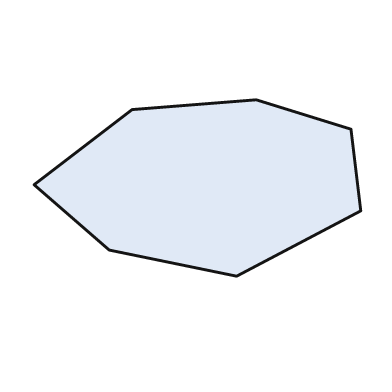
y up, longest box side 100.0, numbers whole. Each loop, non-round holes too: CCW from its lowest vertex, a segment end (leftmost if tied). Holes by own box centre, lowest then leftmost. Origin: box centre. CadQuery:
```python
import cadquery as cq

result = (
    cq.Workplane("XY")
    .moveTo(12.0, -27.0)
    .lineTo(50.0, -7.0)
    .lineTo(47.0, 18.0)
    .lineTo(18.0, 27.0)
    .lineTo(-20.0, 24.0)
    .lineTo(-50.0, 1.0)
    .lineTo(-27.0, -19.0)
    .close()
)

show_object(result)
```